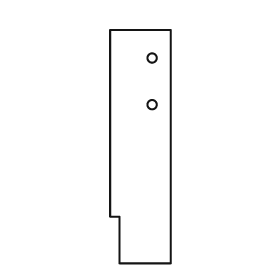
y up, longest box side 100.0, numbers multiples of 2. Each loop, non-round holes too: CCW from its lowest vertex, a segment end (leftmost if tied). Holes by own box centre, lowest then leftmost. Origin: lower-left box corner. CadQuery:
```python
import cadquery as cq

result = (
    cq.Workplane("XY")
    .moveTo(4.0, 0.0)
    .lineTo(26.0, 0.0)
    .lineTo(26.0, 100.0)
    .lineTo(0.0, 100.0)
    .lineTo(0.0, 20.0)
    .lineTo(4.0, 20.0)
    .close()
    .moveTo(18.0, 68.0)
    .circle(2.0)
    .moveTo(18.0, 88.0)
    .circle(2.0)
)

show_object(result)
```